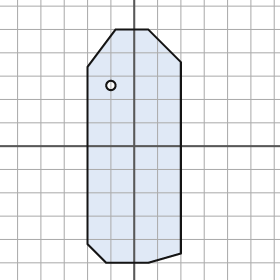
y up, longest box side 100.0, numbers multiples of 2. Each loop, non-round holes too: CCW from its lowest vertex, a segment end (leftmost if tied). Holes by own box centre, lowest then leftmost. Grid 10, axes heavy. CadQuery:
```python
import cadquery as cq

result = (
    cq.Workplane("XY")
    .moveTo(-12.0, -50.0)
    .lineTo(6.0, -50.0)
    .lineTo(20.0, -46.0)
    .lineTo(20.0, 36.0)
    .lineTo(6.0, 50.0)
    .lineTo(-8.0, 50.0)
    .lineTo(-20.0, 34.0)
    .lineTo(-20.0, -42.0)
    .close()
    .moveTo(-10.0, 26.0)
    .circle(2.0)
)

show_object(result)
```